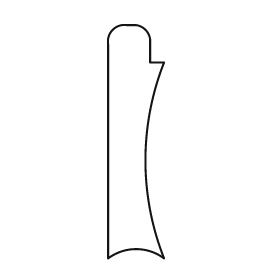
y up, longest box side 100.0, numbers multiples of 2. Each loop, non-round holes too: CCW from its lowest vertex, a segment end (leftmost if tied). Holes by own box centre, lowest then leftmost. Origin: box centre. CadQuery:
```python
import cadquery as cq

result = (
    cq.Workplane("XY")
    .moveTo(-12.0, -50.0)
    .threePointArc((0.0, -46.0), (12.0, -50.0))
    .threePointArc((4.0, -8.0), (12.0, 34.0))
    .lineTo(6.0, 34.0)
    .lineTo(6.0, 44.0)
    .threePointArc((4.0, 48.0), (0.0, 50.0))
    .lineTo(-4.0, 50.0)
    .threePointArc((-10.0, 48.0), (-12.0, 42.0))
    .close()
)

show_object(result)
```